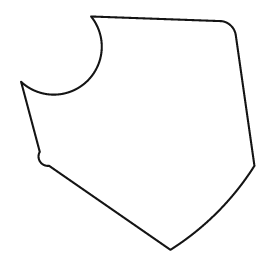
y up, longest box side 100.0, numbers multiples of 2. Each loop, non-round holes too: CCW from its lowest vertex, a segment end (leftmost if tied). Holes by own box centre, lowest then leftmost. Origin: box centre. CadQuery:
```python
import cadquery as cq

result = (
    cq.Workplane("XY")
    .moveTo(14.0, -50.0)
    .threePointArc((34.0, -34.0), (50.0, -14.0))
    .lineTo(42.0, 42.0)
    .threePointArc((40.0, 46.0), (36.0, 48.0))
    .lineTo(-20.0, 50.0)
    .threePointArc((-22.0, 22.0), (-50.0, 22.0))
    .lineTo(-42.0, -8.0)
    .threePointArc((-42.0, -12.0), (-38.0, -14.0))
    .close()
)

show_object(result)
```